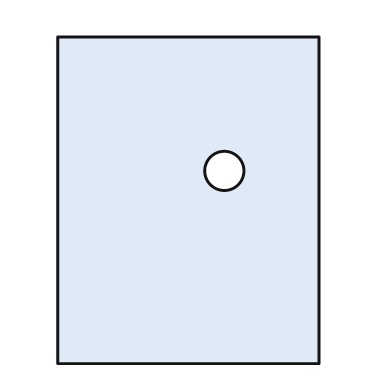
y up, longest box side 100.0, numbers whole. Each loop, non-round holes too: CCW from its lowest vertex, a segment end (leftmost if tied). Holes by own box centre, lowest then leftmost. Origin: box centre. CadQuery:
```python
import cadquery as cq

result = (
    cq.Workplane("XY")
    .moveTo(-40.0, -50.0)
    .lineTo(40.0, -50.0)
    .lineTo(40.0, 50.0)
    .lineTo(-40.0, 50.0)
    .close()
    .moveTo(11.0, 9.0)
    .circle(6.0)
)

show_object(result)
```